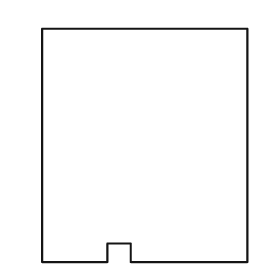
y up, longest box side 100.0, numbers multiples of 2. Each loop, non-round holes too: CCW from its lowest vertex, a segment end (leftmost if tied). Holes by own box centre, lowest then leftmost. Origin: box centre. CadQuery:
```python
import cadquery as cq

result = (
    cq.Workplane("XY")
    .moveTo(-44.0, -50.0)
    .lineTo(-16.0, -50.0)
    .lineTo(-16.0, -42.0)
    .lineTo(-6.0, -42.0)
    .lineTo(-6.0, -50.0)
    .lineTo(44.0, -50.0)
    .lineTo(44.0, 50.0)
    .lineTo(-44.0, 50.0)
    .close()
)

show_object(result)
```